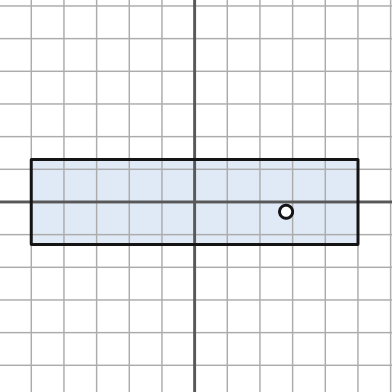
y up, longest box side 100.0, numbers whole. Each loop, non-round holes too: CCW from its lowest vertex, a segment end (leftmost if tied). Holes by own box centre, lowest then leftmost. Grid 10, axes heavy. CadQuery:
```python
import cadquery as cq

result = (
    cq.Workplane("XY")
    .moveTo(-50.0, -13.0)
    .lineTo(50.0, -13.0)
    .lineTo(50.0, 13.0)
    .lineTo(-50.0, 13.0)
    .close()
    .moveTo(28.0, -3.0)
    .circle(2.0)
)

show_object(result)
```